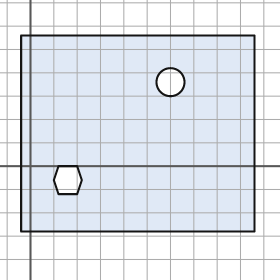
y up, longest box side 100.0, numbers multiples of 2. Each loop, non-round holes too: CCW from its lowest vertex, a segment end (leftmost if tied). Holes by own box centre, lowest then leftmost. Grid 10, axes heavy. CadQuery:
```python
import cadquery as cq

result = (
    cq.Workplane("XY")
    .moveTo(-4.0, -28.0)
    .lineTo(96.0, -28.0)
    .lineTo(96.0, 56.0)
    .lineTo(-4.0, 56.0)
    .close()
    .moveTo(12.0, -12.0)
    .lineTo(20.0, -12.0)
    .lineTo(22.0, -6.0)
    .lineTo(20.0, 0.0)
    .lineTo(12.0, 0.0)
    .lineTo(10.0, -6.0)
    .close()
    .moveTo(60.0, 36.0)
    .circle(6.0)
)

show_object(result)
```